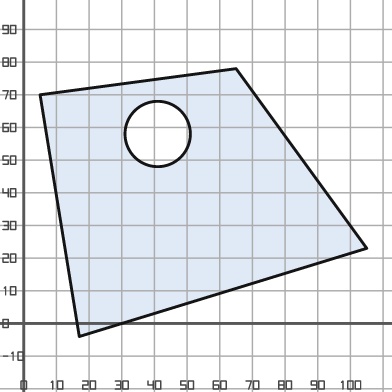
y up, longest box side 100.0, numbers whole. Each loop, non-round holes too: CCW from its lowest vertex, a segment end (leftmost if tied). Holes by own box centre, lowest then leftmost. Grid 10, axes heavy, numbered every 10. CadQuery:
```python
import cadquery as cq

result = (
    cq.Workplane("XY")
    .moveTo(17.0, -4.0)
    .lineTo(105.0, 23.0)
    .lineTo(65.0, 78.0)
    .lineTo(5.0, 70.0)
    .close()
    .moveTo(41.0, 58.0)
    .circle(10.0)
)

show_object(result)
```